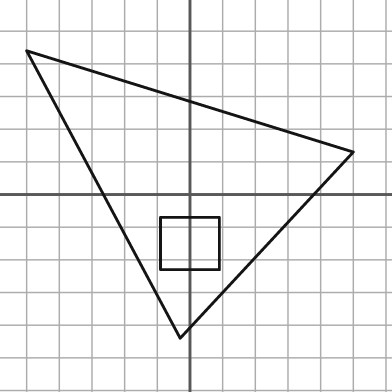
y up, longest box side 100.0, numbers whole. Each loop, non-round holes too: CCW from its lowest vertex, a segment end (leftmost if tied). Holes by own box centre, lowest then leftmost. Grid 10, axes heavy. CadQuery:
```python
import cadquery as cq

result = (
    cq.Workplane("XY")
    .moveTo(-3.0, -44.0)
    .lineTo(50.0, 13.0)
    .lineTo(-50.0, 44.0)
    .close()
    .moveTo(-9.0, -23.0)
    .lineTo(9.0, -23.0)
    .lineTo(9.0, -7.0)
    .lineTo(-9.0, -7.0)
    .close()
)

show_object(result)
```